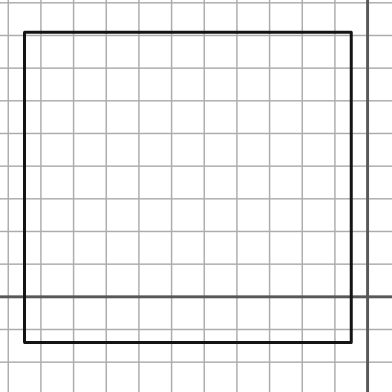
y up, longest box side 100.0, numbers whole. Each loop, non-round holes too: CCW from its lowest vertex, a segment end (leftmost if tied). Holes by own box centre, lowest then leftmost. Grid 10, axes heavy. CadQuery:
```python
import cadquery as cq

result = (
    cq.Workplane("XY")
    .moveTo(-105.0, -14.0)
    .lineTo(-5.0, -14.0)
    .lineTo(-5.0, 81.0)
    .lineTo(-105.0, 81.0)
    .close()
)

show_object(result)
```